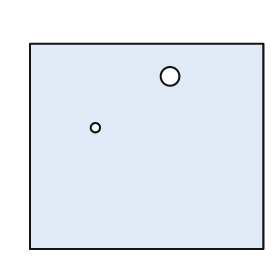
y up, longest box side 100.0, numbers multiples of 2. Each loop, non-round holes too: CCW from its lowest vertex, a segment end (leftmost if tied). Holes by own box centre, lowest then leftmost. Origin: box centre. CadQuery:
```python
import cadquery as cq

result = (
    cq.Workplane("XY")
    .moveTo(-50.0, -44.0)
    .lineTo(50.0, -44.0)
    .lineTo(50.0, 44.0)
    .lineTo(-50.0, 44.0)
    .close()
    .moveTo(-22.0, 8.0)
    .circle(2.0)
    .moveTo(10.0, 30.0)
    .circle(4.0)
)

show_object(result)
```